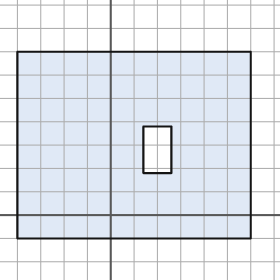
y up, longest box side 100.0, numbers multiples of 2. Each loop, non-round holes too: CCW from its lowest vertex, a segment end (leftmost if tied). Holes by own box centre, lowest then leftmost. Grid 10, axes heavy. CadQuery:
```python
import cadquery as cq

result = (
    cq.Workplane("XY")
    .moveTo(-40.0, -10.0)
    .lineTo(60.0, -10.0)
    .lineTo(60.0, 70.0)
    .lineTo(-40.0, 70.0)
    .close()
    .moveTo(14.0, 18.0)
    .lineTo(26.0, 18.0)
    .lineTo(26.0, 38.0)
    .lineTo(14.0, 38.0)
    .close()
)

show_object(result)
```